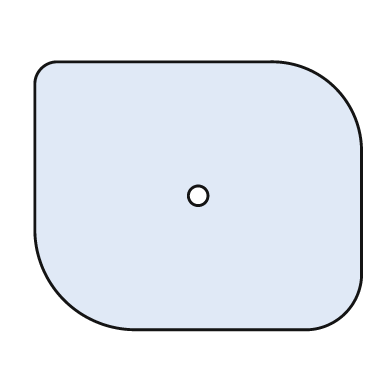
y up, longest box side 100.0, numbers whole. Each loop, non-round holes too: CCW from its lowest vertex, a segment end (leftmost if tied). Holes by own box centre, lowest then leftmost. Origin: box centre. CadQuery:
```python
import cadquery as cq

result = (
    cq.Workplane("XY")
    .moveTo(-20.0, -41.0)
    .lineTo(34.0, -41.0)
    .threePointArc((45.0, -36.0), (50.0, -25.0))
    .lineTo(50.0, 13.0)
    .threePointArc((42.0, 33.0), (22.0, 41.0))
    .lineTo(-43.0, 41.0)
    .threePointArc((-48.0, 39.0), (-50.0, 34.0))
    .lineTo(-50.0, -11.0)
    .threePointArc((-41.0, -32.0), (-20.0, -41.0))
    .close()
    .moveTo(0.0, 0.0)
    .circle(3.0)
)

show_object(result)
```